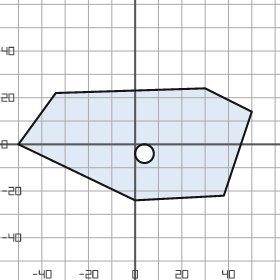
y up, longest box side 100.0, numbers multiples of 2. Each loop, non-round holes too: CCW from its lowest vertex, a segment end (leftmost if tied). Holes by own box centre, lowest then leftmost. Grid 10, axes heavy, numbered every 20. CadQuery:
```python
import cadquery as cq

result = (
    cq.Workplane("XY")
    .moveTo(0.0, -24.0)
    .lineTo(38.0, -22.0)
    .lineTo(50.0, 14.0)
    .lineTo(30.0, 24.0)
    .lineTo(-34.0, 22.0)
    .lineTo(-50.0, 0.0)
    .close()
    .moveTo(4.0, -4.0)
    .circle(4.0)
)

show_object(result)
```